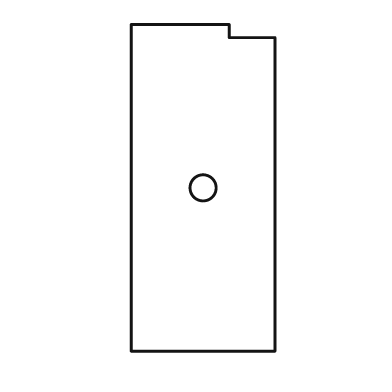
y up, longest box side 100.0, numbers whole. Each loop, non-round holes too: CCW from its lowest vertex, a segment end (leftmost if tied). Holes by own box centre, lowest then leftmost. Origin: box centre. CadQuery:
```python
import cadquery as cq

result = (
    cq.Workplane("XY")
    .moveTo(-22.0, -50.0)
    .lineTo(22.0, -50.0)
    .lineTo(22.0, 46.0)
    .lineTo(8.0, 46.0)
    .lineTo(8.0, 50.0)
    .lineTo(-22.0, 50.0)
    .close()
    .moveTo(0.0, 0.0)
    .circle(4.0)
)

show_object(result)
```